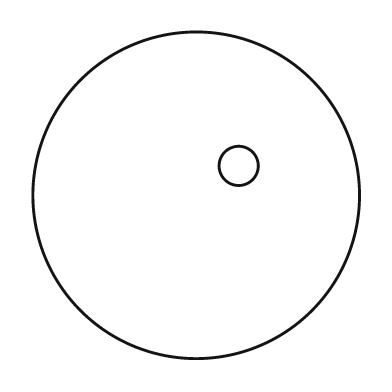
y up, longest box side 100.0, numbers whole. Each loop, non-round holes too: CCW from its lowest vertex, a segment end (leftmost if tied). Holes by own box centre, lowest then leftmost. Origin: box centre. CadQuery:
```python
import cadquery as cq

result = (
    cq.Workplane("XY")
    .moveTo(0.0, 0.0)
    .circle(50.0)
    .moveTo(13.0, 9.0)
    .circle(6.0)
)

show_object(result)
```